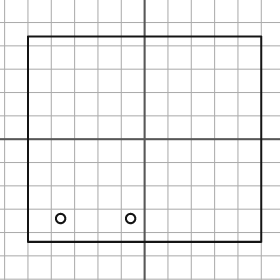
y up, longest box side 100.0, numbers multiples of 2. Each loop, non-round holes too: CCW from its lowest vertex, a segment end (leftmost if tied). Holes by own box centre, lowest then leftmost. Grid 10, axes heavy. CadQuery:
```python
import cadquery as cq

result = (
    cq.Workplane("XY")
    .moveTo(-50.0, -44.0)
    .lineTo(50.0, -44.0)
    .lineTo(50.0, 44.0)
    .lineTo(-50.0, 44.0)
    .close()
    .moveTo(-36.0, -34.0)
    .circle(2.0)
    .moveTo(-6.0, -34.0)
    .circle(2.0)
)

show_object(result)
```